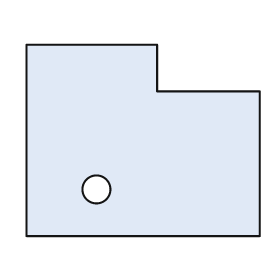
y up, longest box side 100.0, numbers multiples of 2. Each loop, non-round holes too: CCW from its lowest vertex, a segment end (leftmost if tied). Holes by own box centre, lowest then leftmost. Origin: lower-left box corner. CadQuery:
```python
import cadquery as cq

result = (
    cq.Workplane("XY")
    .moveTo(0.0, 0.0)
    .lineTo(100.0, 0.0)
    .lineTo(100.0, 62.0)
    .lineTo(56.0, 62.0)
    .lineTo(56.0, 82.0)
    .lineTo(0.0, 82.0)
    .close()
    .moveTo(30.0, 20.0)
    .circle(6.0)
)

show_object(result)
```